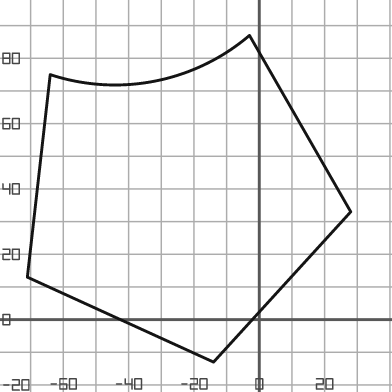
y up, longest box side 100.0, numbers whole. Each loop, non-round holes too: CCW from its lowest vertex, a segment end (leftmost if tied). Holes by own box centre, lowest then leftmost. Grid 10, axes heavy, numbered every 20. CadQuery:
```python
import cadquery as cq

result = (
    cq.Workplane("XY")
    .moveTo(-14.0, -13.0)
    .lineTo(28.0, 33.0)
    .lineTo(-3.0, 87.0)
    .threePointArc((-32.0, 73.0), (-64.0, 75.0))
    .lineTo(-71.0, 13.0)
    .close()
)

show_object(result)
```